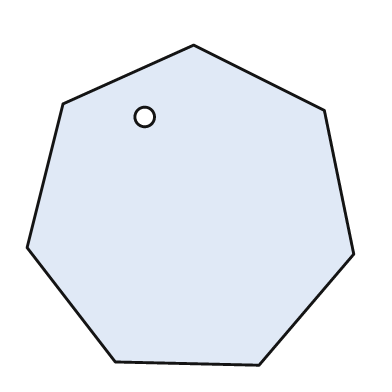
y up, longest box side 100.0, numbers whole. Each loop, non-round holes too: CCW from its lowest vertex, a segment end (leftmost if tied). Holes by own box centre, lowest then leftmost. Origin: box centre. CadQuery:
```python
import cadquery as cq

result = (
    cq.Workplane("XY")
    .moveTo(21.0, -49.0)
    .lineTo(50.0, -15.0)
    .lineTo(41.0, 29.0)
    .lineTo(1.0, 49.0)
    .lineTo(-39.0, 31.0)
    .lineTo(-50.0, -13.0)
    .lineTo(-23.0, -48.0)
    .close()
    .moveTo(-14.0, 27.0)
    .circle(3.0)
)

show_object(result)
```